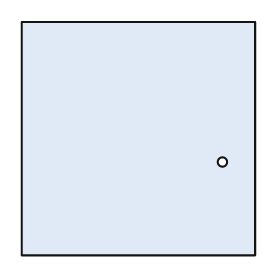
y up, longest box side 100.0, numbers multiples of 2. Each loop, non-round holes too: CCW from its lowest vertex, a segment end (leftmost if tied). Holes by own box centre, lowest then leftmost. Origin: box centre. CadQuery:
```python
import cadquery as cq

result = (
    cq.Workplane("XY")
    .moveTo(-50.0, -50.0)
    .lineTo(50.0, -50.0)
    .lineTo(50.0, 50.0)
    .lineTo(-50.0, 50.0)
    .close()
    .moveTo(36.0, -10.0)
    .circle(2.0)
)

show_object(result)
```